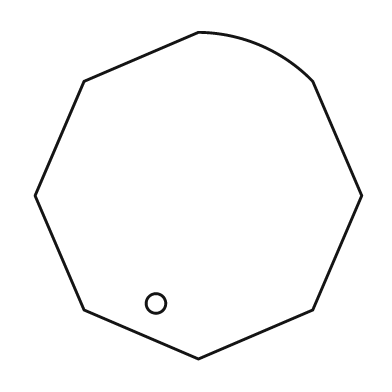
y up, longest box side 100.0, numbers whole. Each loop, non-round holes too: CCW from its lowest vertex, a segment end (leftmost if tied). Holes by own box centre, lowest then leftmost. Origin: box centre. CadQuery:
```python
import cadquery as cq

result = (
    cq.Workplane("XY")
    .moveTo(0.0, -50.0)
    .lineTo(35.0, -35.0)
    .lineTo(50.0, 0.0)
    .lineTo(35.0, 35.0)
    .threePointArc((19.0, 46.0), (0.0, 50.0))
    .lineTo(-35.0, 35.0)
    .lineTo(-50.0, 0.0)
    .lineTo(-35.0, -35.0)
    .close()
    .moveTo(-13.0, -33.0)
    .circle(3.0)
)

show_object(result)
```